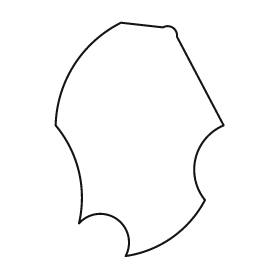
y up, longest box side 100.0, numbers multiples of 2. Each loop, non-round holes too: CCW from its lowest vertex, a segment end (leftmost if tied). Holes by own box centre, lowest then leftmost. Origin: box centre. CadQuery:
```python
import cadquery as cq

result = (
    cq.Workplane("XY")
    .moveTo(-6.0, -50.0)
    .threePointArc((14.0, -42.0), (28.0, -26.0))
    .threePointArc((24.0, -8.0), (36.0, 6.0))
    .lineTo(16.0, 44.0)
    .threePointArc((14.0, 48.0), (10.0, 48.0))
    .lineTo(-8.0, 50.0)
    .threePointArc((-28.0, 32.0), (-36.0, 6.0))
    .threePointArc((-26.0, -14.0), (-26.0, -36.0))
    .threePointArc((-10.0, -34.0), (-6.0, -50.0))
    .close()
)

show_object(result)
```